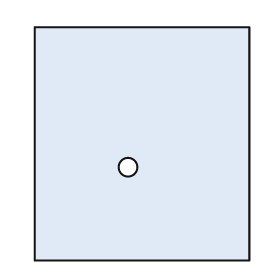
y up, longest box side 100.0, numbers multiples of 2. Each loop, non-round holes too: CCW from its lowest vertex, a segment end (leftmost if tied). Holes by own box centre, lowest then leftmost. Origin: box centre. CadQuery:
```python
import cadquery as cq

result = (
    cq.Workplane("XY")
    .moveTo(-46.0, -50.0)
    .lineTo(46.0, -50.0)
    .lineTo(46.0, 50.0)
    .lineTo(-46.0, 50.0)
    .close()
    .moveTo(-6.0, -10.0)
    .circle(4.0)
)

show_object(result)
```